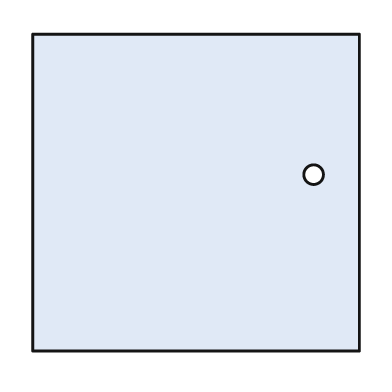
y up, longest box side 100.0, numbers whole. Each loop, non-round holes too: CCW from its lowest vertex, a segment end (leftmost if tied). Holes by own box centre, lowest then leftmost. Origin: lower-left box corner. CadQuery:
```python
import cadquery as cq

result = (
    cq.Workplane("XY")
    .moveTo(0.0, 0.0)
    .lineTo(100.0, 0.0)
    .lineTo(100.0, 97.0)
    .lineTo(0.0, 97.0)
    .close()
    .moveTo(86.0, 54.0)
    .circle(3.0)
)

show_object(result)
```